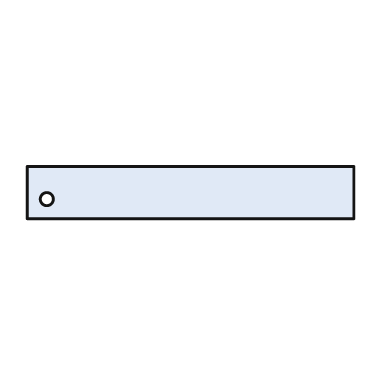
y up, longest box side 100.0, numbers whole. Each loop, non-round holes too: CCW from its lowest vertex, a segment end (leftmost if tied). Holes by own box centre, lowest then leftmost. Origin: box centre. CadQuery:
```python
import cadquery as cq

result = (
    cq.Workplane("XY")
    .moveTo(-50.0, -8.0)
    .lineTo(50.0, -8.0)
    .lineTo(50.0, 8.0)
    .lineTo(-50.0, 8.0)
    .close()
    .moveTo(-44.0, -2.0)
    .circle(2.0)
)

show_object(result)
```